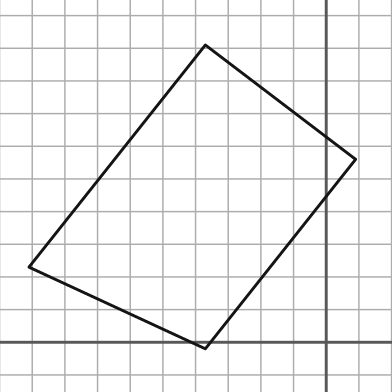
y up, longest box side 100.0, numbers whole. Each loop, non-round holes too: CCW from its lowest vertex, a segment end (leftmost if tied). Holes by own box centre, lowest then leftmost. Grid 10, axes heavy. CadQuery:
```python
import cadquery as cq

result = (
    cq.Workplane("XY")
    .moveTo(-37.0, -2.0)
    .lineTo(9.0, 56.0)
    .lineTo(-37.0, 91.0)
    .lineTo(-91.0, 23.0)
    .close()
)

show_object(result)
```